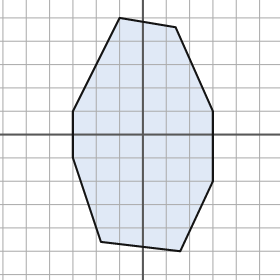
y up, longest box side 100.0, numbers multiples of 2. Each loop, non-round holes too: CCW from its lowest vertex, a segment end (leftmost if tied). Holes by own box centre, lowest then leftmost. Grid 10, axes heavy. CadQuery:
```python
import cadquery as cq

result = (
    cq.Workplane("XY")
    .moveTo(16.0, -50.0)
    .lineTo(30.0, -20.0)
    .lineTo(30.0, 10.0)
    .lineTo(14.0, 46.0)
    .lineTo(-10.0, 50.0)
    .lineTo(-30.0, 10.0)
    .lineTo(-30.0, -10.0)
    .lineTo(-18.0, -46.0)
    .close()
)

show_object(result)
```